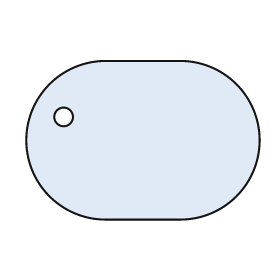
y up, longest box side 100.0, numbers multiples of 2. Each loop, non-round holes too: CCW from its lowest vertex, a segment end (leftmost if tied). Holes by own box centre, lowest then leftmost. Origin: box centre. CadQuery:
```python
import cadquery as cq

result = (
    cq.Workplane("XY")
    .moveTo(-16.0, -34.0)
    .lineTo(16.0, -34.0)
    .threePointArc((50.0, 0.0), (16.0, 34.0))
    .lineTo(-16.0, 34.0)
    .threePointArc((-50.0, 0.0), (-16.0, -34.0))
    .close()
    .moveTo(-34.0, 10.0)
    .circle(4.0)
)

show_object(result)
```